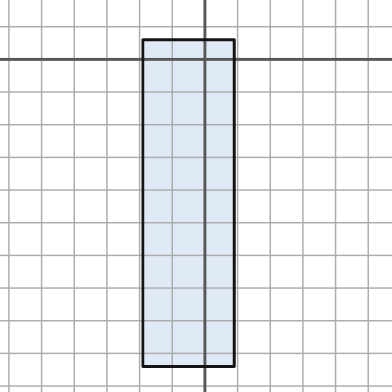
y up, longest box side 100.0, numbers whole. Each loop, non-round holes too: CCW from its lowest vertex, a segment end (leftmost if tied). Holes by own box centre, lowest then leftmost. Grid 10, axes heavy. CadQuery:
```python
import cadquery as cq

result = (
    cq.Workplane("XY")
    .moveTo(-19.0, -94.0)
    .lineTo(9.0, -94.0)
    .lineTo(9.0, 6.0)
    .lineTo(-19.0, 6.0)
    .close()
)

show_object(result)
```